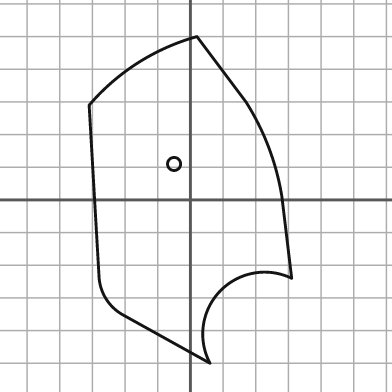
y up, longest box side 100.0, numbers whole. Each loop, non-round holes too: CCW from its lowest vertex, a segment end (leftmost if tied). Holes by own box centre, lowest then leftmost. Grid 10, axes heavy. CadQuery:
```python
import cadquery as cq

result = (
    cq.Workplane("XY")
    .moveTo(6.0, -50.0)
    .threePointArc((9.0, -28.0), (31.0, -24.0))
    .lineTo(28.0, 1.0)
    .threePointArc((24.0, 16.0), (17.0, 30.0))
    .lineTo(2.0, 50.0)
    .threePointArc((-16.0, 42.0), (-31.0, 29.0))
    .lineTo(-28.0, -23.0)
    .threePointArc((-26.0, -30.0), (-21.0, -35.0))
    .close()
    .moveTo(-5.0, 11.0)
    .circle(2.0)
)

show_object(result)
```